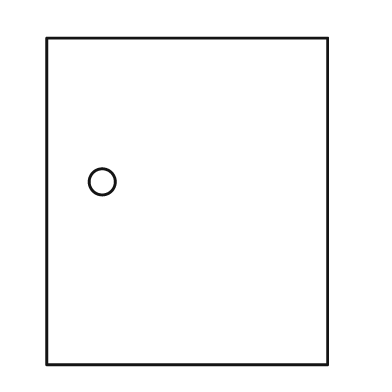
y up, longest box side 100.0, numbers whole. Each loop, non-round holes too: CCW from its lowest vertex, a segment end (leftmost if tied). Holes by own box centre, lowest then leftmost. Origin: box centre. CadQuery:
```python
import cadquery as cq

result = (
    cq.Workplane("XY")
    .moveTo(-43.0, -50.0)
    .lineTo(43.0, -50.0)
    .lineTo(43.0, 50.0)
    .lineTo(-43.0, 50.0)
    .close()
    .moveTo(-26.0, 6.0)
    .circle(4.0)
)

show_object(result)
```